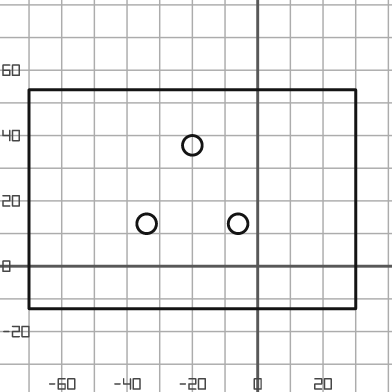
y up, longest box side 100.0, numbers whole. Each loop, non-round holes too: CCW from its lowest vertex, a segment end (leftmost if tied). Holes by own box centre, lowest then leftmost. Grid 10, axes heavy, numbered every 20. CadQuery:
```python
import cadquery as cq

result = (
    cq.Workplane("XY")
    .moveTo(-70.0, -13.0)
    .lineTo(30.0, -13.0)
    .lineTo(30.0, 54.0)
    .lineTo(-70.0, 54.0)
    .close()
    .moveTo(-34.0, 13.0)
    .circle(3.0)
    .moveTo(-6.0, 13.0)
    .circle(3.0)
    .moveTo(-20.0, 37.0)
    .circle(3.0)
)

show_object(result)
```